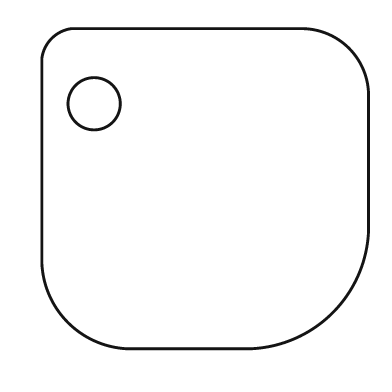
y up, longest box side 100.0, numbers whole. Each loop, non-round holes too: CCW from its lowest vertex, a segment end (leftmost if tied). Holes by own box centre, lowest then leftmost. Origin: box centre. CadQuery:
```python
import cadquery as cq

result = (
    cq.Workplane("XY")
    .moveTo(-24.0, -49.0)
    .lineTo(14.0, -49.0)
    .threePointArc((39.0, -38.0), (50.0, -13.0))
    .lineTo(50.0, 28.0)
    .threePointArc((44.0, 43.0), (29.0, 49.0))
    .lineTo(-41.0, 49.0)
    .threePointArc((-47.0, 46.0), (-50.0, 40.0))
    .lineTo(-50.0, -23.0)
    .threePointArc((-42.0, -41.0), (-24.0, -49.0))
    .close()
    .moveTo(-34.0, 26.0)
    .circle(8.0)
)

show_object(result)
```